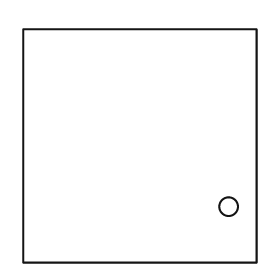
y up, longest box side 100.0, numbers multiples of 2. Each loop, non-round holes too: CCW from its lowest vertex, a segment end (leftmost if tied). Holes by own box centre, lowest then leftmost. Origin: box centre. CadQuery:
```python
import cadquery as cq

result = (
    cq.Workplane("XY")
    .moveTo(-50.0, -50.0)
    .lineTo(50.0, -50.0)
    .lineTo(50.0, 50.0)
    .lineTo(-50.0, 50.0)
    .close()
    .moveTo(38.0, -26.0)
    .circle(4.0)
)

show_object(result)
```